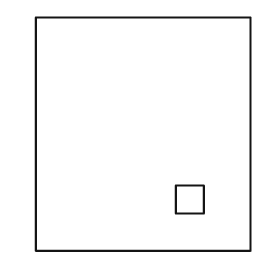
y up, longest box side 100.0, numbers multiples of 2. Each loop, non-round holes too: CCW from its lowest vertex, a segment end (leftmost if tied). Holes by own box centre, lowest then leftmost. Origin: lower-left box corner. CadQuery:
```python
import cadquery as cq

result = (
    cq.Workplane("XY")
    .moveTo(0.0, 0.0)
    .lineTo(92.0, 0.0)
    .lineTo(92.0, 100.0)
    .lineTo(0.0, 100.0)
    .close()
    .moveTo(60.0, 16.0)
    .lineTo(72.0, 16.0)
    .lineTo(72.0, 28.0)
    .lineTo(60.0, 28.0)
    .close()
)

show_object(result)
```